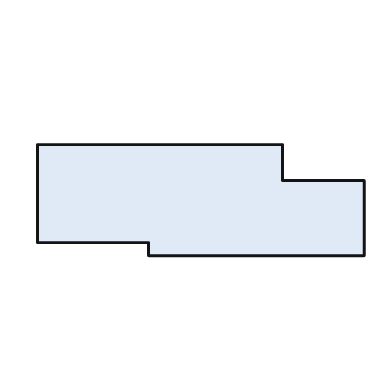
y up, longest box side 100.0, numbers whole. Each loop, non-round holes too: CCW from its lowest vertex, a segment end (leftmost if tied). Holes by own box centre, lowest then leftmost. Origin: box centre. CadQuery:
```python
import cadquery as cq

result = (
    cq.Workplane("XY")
    .moveTo(-16.0, -17.0)
    .lineTo(50.0, -17.0)
    .lineTo(50.0, 6.0)
    .lineTo(25.0, 6.0)
    .lineTo(25.0, 17.0)
    .lineTo(-50.0, 17.0)
    .lineTo(-50.0, -13.0)
    .lineTo(-16.0, -13.0)
    .close()
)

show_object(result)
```